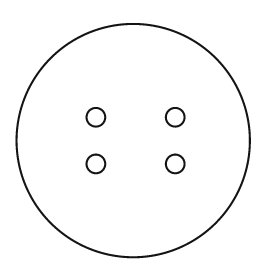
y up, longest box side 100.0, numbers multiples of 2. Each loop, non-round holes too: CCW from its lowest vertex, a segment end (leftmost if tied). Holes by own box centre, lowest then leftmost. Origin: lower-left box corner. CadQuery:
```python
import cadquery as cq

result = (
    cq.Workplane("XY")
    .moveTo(50.0, 50.0)
    .circle(50.0)
    .moveTo(34.0, 40.0)
    .circle(4.0)
    .moveTo(68.0, 40.0)
    .circle(4.0)
    .moveTo(34.0, 60.0)
    .circle(4.0)
    .moveTo(68.0, 60.0)
    .circle(4.0)
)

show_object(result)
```